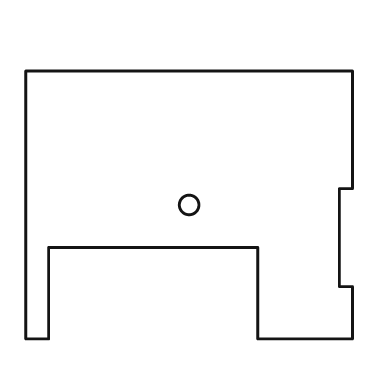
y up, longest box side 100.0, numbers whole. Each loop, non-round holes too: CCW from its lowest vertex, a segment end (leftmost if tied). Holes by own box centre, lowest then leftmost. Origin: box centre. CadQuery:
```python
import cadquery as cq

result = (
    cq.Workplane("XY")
    .moveTo(-50.0, -41.0)
    .lineTo(-43.0, -41.0)
    .lineTo(-43.0, -13.0)
    .lineTo(21.0, -13.0)
    .lineTo(21.0, -41.0)
    .lineTo(50.0, -41.0)
    .lineTo(50.0, -25.0)
    .lineTo(46.0, -25.0)
    .lineTo(46.0, 5.0)
    .lineTo(50.0, 5.0)
    .lineTo(50.0, 41.0)
    .lineTo(-50.0, 41.0)
    .close()
    .moveTo(0.0, 0.0)
    .circle(3.0)
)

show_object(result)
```